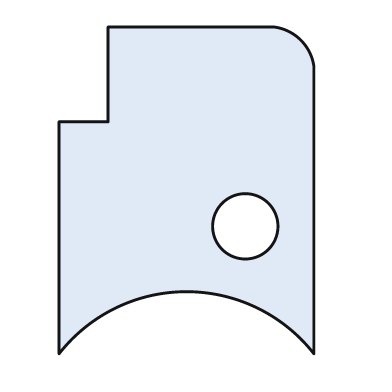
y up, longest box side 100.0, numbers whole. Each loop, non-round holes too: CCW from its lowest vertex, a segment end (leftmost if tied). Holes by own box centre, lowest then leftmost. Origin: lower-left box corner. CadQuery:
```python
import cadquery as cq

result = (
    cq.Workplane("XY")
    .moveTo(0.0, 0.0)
    .threePointArc((39.0, 19.0), (78.0, 0.0))
    .lineTo(78.0, 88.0)
    .threePointArc((74.0, 96.0), (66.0, 100.0))
    .lineTo(15.0, 100.0)
    .lineTo(15.0, 71.0)
    .lineTo(0.0, 71.0)
    .close()
    .moveTo(57.0, 39.0)
    .circle(10.0)
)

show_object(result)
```